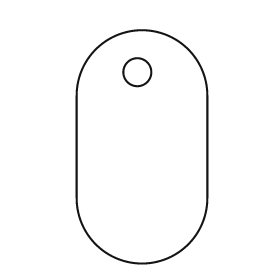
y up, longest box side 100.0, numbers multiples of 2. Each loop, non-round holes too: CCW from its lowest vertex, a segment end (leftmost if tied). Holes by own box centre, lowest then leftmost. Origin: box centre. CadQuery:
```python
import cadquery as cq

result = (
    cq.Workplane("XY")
    .moveTo(-28.0, -22.0)
    .threePointArc((0.0, -50.0), (28.0, -22.0))
    .lineTo(28.0, 22.0)
    .threePointArc((0.0, 50.0), (-28.0, 22.0))
    .close()
    .moveTo(-2.0, 32.0)
    .circle(6.0)
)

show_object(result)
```